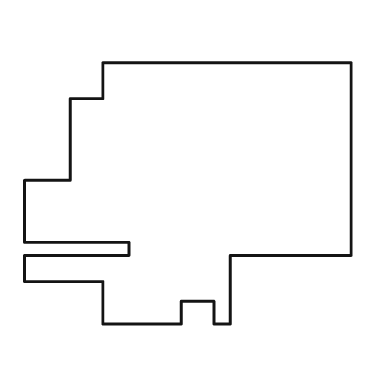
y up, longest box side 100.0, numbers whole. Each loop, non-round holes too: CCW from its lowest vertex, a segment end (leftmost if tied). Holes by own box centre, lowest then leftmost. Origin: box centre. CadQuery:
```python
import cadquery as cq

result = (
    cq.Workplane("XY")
    .moveTo(-26.0, -40.0)
    .lineTo(-2.0, -40.0)
    .lineTo(-2.0, -33.0)
    .lineTo(8.0, -33.0)
    .lineTo(8.0, -40.0)
    .lineTo(13.0, -40.0)
    .lineTo(13.0, -19.0)
    .lineTo(50.0, -19.0)
    .lineTo(50.0, 40.0)
    .lineTo(-26.0, 40.0)
    .lineTo(-26.0, 29.0)
    .lineTo(-36.0, 29.0)
    .lineTo(-36.0, 4.0)
    .lineTo(-50.0, 4.0)
    .lineTo(-50.0, -15.0)
    .lineTo(-18.0, -15.0)
    .lineTo(-18.0, -19.0)
    .lineTo(-50.0, -19.0)
    .lineTo(-50.0, -27.0)
    .lineTo(-26.0, -27.0)
    .close()
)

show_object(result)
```